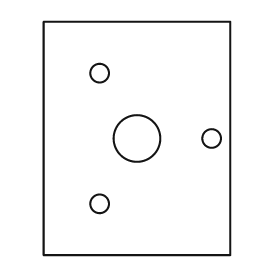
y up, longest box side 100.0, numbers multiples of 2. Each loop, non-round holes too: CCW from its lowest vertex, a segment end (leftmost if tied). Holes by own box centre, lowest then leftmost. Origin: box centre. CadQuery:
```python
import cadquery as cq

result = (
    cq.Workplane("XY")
    .moveTo(-40.0, -50.0)
    .lineTo(40.0, -50.0)
    .lineTo(40.0, 50.0)
    .lineTo(-40.0, 50.0)
    .close()
    .moveTo(-16.0, -28.0)
    .circle(4.0)
    .moveTo(0.0, 0.0)
    .circle(10.0)
    .moveTo(32.0, 0.0)
    .circle(4.0)
    .moveTo(-16.0, 28.0)
    .circle(4.0)
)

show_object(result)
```